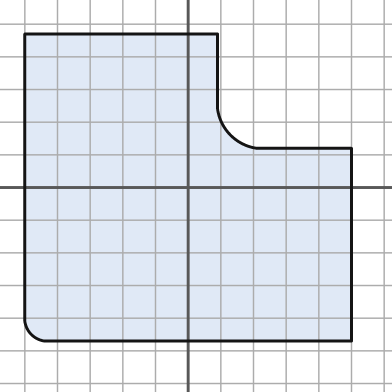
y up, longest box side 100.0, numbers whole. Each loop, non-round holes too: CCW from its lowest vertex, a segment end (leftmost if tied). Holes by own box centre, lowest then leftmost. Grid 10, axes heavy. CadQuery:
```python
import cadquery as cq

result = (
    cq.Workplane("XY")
    .moveTo(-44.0, -47.0)
    .lineTo(50.0, -47.0)
    .lineTo(50.0, 12.0)
    .lineTo(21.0, 12.0)
    .threePointArc((13.0, 16.0), (9.0, 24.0))
    .lineTo(9.0, 47.0)
    .lineTo(-50.0, 47.0)
    .lineTo(-50.0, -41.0)
    .threePointArc((-48.0, -45.0), (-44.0, -47.0))
    .close()
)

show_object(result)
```